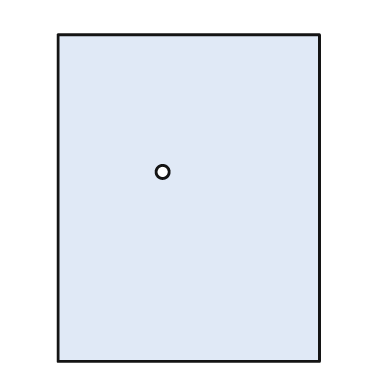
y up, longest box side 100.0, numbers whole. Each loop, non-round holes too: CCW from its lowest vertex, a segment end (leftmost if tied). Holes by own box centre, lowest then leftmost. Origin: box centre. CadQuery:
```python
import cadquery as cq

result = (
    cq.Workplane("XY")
    .moveTo(-40.0, -50.0)
    .lineTo(40.0, -50.0)
    .lineTo(40.0, 50.0)
    .lineTo(-40.0, 50.0)
    .close()
    .moveTo(-8.0, 8.0)
    .circle(2.0)
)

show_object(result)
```